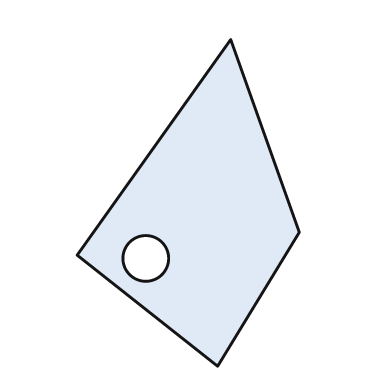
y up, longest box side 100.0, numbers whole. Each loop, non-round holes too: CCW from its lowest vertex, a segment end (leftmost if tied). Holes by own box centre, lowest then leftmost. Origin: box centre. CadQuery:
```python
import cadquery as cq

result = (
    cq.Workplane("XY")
    .moveTo(9.0, -50.0)
    .lineTo(34.0, -9.0)
    .lineTo(13.0, 50.0)
    .lineTo(-34.0, -16.0)
    .close()
    .moveTo(-13.0, -17.0)
    .circle(7.0)
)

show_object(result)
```